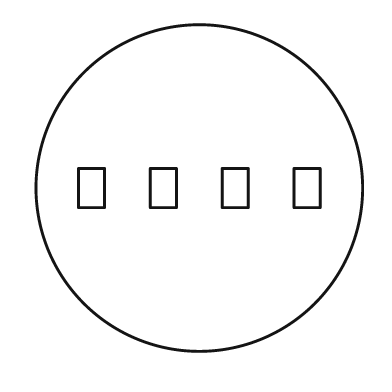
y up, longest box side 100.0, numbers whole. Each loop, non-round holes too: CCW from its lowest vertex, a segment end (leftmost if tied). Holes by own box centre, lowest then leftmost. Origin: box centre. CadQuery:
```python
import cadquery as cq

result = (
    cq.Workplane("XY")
    .moveTo(0.0, 0.0)
    .circle(50.0)
    .moveTo(-37.0, -6.0)
    .lineTo(-29.0, -6.0)
    .lineTo(-29.0, 6.0)
    .lineTo(-37.0, 6.0)
    .close()
    .moveTo(-15.0, -6.0)
    .lineTo(-7.0, -6.0)
    .lineTo(-7.0, 6.0)
    .lineTo(-15.0, 6.0)
    .close()
    .moveTo(7.0, -6.0)
    .lineTo(15.0, -6.0)
    .lineTo(15.0, 6.0)
    .lineTo(7.0, 6.0)
    .close()
    .moveTo(29.0, -6.0)
    .lineTo(37.0, -6.0)
    .lineTo(37.0, 6.0)
    .lineTo(29.0, 6.0)
    .close()
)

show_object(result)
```